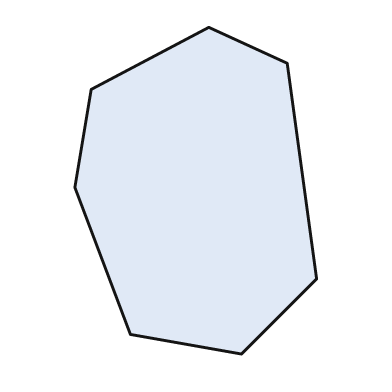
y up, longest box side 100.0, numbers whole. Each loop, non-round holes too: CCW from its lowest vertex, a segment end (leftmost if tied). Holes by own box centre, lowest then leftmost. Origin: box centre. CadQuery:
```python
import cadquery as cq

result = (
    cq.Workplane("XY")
    .moveTo(14.0, -50.0)
    .lineTo(37.0, -27.0)
    .lineTo(28.0, 39.0)
    .lineTo(4.0, 50.0)
    .lineTo(-32.0, 31.0)
    .lineTo(-37.0, 1.0)
    .lineTo(-20.0, -44.0)
    .close()
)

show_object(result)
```